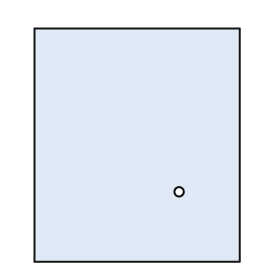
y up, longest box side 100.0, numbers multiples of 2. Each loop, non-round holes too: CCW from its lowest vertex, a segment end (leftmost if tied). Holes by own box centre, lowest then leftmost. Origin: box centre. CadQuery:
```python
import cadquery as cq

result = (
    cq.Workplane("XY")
    .moveTo(-44.0, -50.0)
    .lineTo(44.0, -50.0)
    .lineTo(44.0, 50.0)
    .lineTo(-44.0, 50.0)
    .close()
    .moveTo(18.0, -20.0)
    .circle(2.0)
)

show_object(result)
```